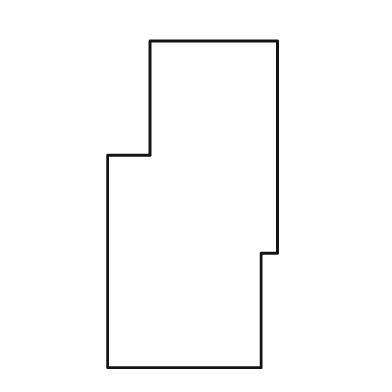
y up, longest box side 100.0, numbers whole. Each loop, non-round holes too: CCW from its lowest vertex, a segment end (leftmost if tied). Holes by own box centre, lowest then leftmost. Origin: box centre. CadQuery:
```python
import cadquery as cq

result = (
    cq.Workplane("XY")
    .moveTo(-26.0, -50.0)
    .lineTo(21.0, -50.0)
    .lineTo(21.0, -15.0)
    .lineTo(26.0, -15.0)
    .lineTo(26.0, 50.0)
    .lineTo(-13.0, 50.0)
    .lineTo(-13.0, 15.0)
    .lineTo(-26.0, 15.0)
    .close()
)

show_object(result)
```